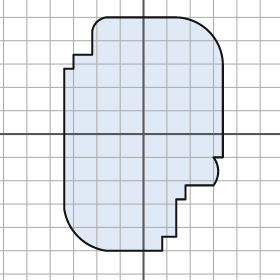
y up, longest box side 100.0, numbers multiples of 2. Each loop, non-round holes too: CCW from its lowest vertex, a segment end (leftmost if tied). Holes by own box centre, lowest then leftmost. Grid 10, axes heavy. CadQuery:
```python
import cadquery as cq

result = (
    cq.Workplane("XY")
    .moveTo(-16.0, -50.0)
    .lineTo(8.0, -50.0)
    .lineTo(8.0, -44.0)
    .lineTo(14.0, -44.0)
    .lineTo(14.0, -28.0)
    .lineTo(18.0, -28.0)
    .lineTo(18.0, -22.0)
    .lineTo(30.0, -22.0)
    .threePointArc((32.0, -16.0), (30.0, -10.0))
    .lineTo(34.0, -10.0)
    .lineTo(34.0, 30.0)
    .threePointArc((28.0, 44.0), (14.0, 50.0))
    .lineTo(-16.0, 50.0)
    .threePointArc((-20.0, 48.0), (-22.0, 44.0))
    .lineTo(-22.0, 34.0)
    .lineTo(-30.0, 34.0)
    .lineTo(-30.0, 28.0)
    .lineTo(-34.0, 28.0)
    .lineTo(-34.0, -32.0)
    .threePointArc((-28.0, -44.0), (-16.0, -50.0))
    .close()
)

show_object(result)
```